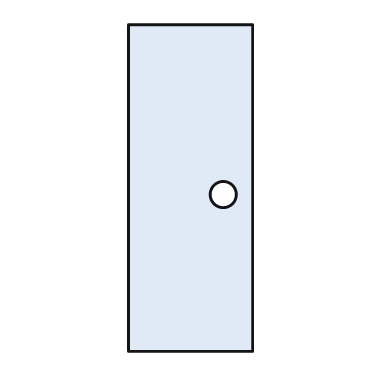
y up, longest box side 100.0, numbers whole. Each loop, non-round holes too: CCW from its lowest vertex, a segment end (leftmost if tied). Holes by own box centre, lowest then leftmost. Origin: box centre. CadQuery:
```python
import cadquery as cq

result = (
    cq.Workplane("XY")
    .moveTo(-19.0, -50.0)
    .lineTo(19.0, -50.0)
    .lineTo(19.0, 50.0)
    .lineTo(-19.0, 50.0)
    .close()
    .moveTo(10.0, -2.0)
    .circle(4.0)
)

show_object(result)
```